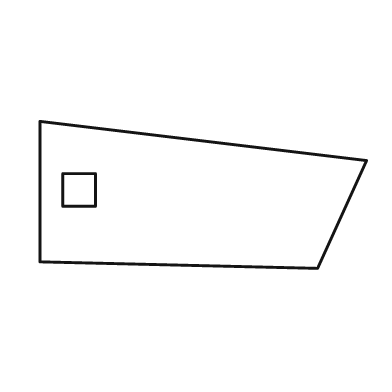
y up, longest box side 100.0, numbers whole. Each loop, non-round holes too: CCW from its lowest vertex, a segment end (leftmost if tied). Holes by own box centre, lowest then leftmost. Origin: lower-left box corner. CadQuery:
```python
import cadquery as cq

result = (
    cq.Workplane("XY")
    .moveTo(85.0, 0.0)
    .lineTo(100.0, 33.0)
    .lineTo(0.0, 45.0)
    .lineTo(0.0, 2.0)
    .close()
    .moveTo(7.0, 19.0)
    .lineTo(17.0, 19.0)
    .lineTo(17.0, 29.0)
    .lineTo(7.0, 29.0)
    .close()
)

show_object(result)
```